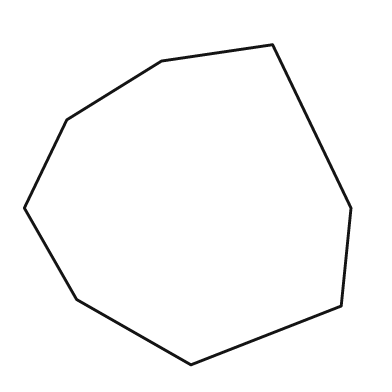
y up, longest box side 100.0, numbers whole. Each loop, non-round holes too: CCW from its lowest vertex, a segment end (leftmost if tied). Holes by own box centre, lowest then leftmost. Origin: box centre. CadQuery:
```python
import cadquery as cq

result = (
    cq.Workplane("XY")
    .moveTo(1.0, -49.0)
    .lineTo(47.0, -31.0)
    .lineTo(50.0, -1.0)
    .lineTo(26.0, 49.0)
    .lineTo(-8.0, 44.0)
    .lineTo(-37.0, 26.0)
    .lineTo(-50.0, -1.0)
    .lineTo(-34.0, -29.0)
    .close()
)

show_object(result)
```